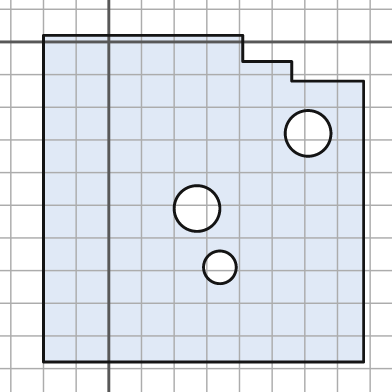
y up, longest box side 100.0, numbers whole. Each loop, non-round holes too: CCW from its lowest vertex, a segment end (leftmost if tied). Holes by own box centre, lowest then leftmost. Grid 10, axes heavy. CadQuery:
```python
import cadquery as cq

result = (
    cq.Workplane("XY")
    .moveTo(-20.0, -98.0)
    .lineTo(78.0, -98.0)
    .lineTo(78.0, -12.0)
    .lineTo(56.0, -12.0)
    .lineTo(56.0, -6.0)
    .lineTo(41.0, -6.0)
    .lineTo(41.0, 2.0)
    .lineTo(-20.0, 2.0)
    .close()
    .moveTo(34.0, -69.0)
    .circle(5.0)
    .moveTo(27.0, -51.0)
    .circle(7.0)
    .moveTo(61.0, -28.0)
    .circle(7.0)
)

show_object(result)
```